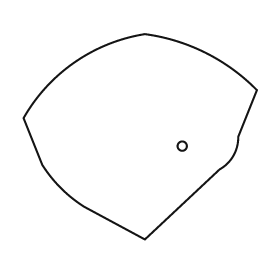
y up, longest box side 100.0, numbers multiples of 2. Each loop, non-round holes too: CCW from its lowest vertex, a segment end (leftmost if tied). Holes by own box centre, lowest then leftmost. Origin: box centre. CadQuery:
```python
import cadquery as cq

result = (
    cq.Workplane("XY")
    .moveTo(2.0, -44.0)
    .lineTo(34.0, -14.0)
    .threePointArc((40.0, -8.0), (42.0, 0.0))
    .lineTo(50.0, 20.0)
    .threePointArc((28.0, 36.0), (2.0, 44.0))
    .threePointArc((-28.0, 32.0), (-50.0, 8.0))
    .lineTo(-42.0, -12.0)
    .threePointArc((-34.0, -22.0), (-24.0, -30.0))
    .close()
    .moveTo(18.0, -4.0)
    .circle(2.0)
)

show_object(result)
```